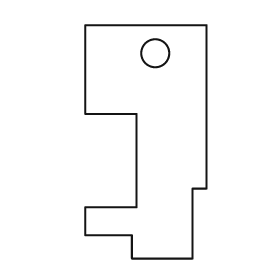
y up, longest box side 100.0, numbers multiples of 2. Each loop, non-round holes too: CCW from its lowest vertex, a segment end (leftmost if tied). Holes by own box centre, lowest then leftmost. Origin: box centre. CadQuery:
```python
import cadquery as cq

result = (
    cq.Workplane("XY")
    .moveTo(-6.0, -50.0)
    .lineTo(20.0, -50.0)
    .lineTo(20.0, -20.0)
    .lineTo(26.0, -20.0)
    .lineTo(26.0, 50.0)
    .lineTo(-26.0, 50.0)
    .lineTo(-26.0, 12.0)
    .lineTo(-4.0, 12.0)
    .lineTo(-4.0, -28.0)
    .lineTo(-26.0, -28.0)
    .lineTo(-26.0, -40.0)
    .lineTo(-6.0, -40.0)
    .close()
    .moveTo(4.0, 38.0)
    .circle(6.0)
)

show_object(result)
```